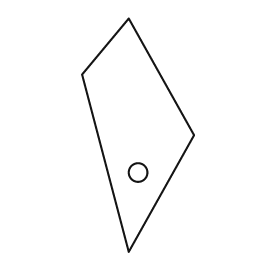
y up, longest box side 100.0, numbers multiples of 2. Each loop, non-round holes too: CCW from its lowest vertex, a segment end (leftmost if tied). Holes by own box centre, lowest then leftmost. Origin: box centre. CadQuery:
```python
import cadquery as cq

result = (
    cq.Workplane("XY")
    .moveTo(-4.0, -50.0)
    .lineTo(24.0, 0.0)
    .lineTo(-4.0, 50.0)
    .lineTo(-24.0, 26.0)
    .close()
    .moveTo(0.0, -16.0)
    .circle(4.0)
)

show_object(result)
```